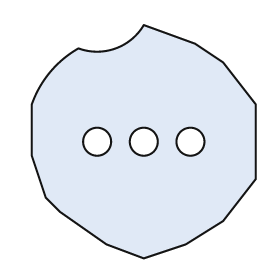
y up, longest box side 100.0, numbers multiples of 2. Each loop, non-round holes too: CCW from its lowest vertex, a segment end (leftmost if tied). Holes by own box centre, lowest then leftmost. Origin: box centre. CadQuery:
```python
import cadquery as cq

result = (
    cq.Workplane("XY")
    .moveTo(0.0, -50.0)
    .lineTo(18.0, -44.0)
    .lineTo(34.0, -34.0)
    .lineTo(48.0, -16.0)
    .lineTo(48.0, 16.0)
    .lineTo(34.0, 34.0)
    .lineTo(22.0, 42.0)
    .lineTo(0.0, 50.0)
    .threePointArc((-12.0, 40.0), (-28.0, 40.0))
    .threePointArc((-40.0, 30.0), (-48.0, 16.0))
    .lineTo(-48.0, -6.0)
    .lineTo(-42.0, -24.0)
    .lineTo(-36.0, -30.0)
    .lineTo(-16.0, -44.0)
    .close()
    .moveTo(-20.0, 0.0)
    .circle(6.0)
    .moveTo(0.0, 0.0)
    .circle(6.0)
    .moveTo(20.0, 0.0)
    .circle(6.0)
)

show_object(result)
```